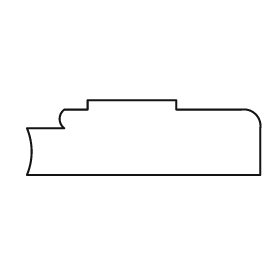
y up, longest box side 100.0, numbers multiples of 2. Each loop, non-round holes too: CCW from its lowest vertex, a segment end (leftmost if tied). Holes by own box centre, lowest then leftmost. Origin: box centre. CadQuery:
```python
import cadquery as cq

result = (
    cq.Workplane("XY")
    .moveTo(-50.0, -16.0)
    .lineTo(50.0, -16.0)
    .lineTo(50.0, 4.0)
    .threePointArc((48.0, 10.0), (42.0, 12.0))
    .lineTo(14.0, 12.0)
    .lineTo(14.0, 16.0)
    .lineTo(-24.0, 16.0)
    .lineTo(-24.0, 12.0)
    .lineTo(-34.0, 12.0)
    .threePointArc((-36.0, 8.0), (-34.0, 4.0))
    .lineTo(-50.0, 4.0)
    .threePointArc((-48.0, -6.0), (-50.0, -16.0))
    .close()
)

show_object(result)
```